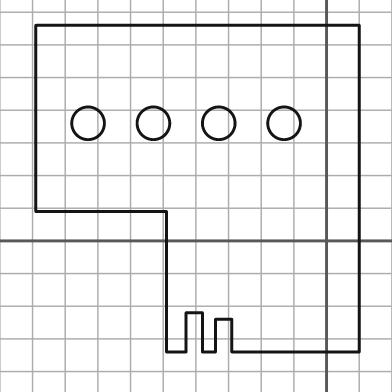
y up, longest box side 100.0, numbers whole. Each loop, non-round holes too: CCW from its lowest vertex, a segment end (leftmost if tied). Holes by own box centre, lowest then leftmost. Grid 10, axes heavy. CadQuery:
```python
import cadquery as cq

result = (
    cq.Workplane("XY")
    .moveTo(-49.0, -34.0)
    .lineTo(-43.0, -34.0)
    .lineTo(-43.0, -22.0)
    .lineTo(-38.0, -22.0)
    .lineTo(-38.0, -34.0)
    .lineTo(-34.0, -34.0)
    .lineTo(-34.0, -24.0)
    .lineTo(-29.0, -24.0)
    .lineTo(-29.0, -34.0)
    .lineTo(10.0, -34.0)
    .lineTo(10.0, 66.0)
    .lineTo(-89.0, 66.0)
    .lineTo(-89.0, 9.0)
    .lineTo(-49.0, 9.0)
    .close()
    .moveTo(-73.0, 36.0)
    .circle(5.0)
    .moveTo(-53.0, 36.0)
    .circle(5.0)
    .moveTo(-33.0, 36.0)
    .circle(5.0)
    .moveTo(-13.0, 36.0)
    .circle(5.0)
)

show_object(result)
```